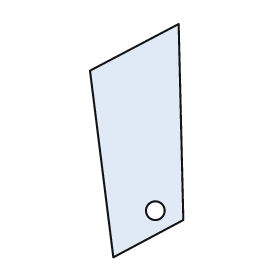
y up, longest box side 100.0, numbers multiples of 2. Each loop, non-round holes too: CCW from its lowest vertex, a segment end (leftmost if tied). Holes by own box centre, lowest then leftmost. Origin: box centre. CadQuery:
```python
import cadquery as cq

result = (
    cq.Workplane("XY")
    .moveTo(-10.0, -50.0)
    .lineTo(20.0, -34.0)
    .lineTo(18.0, 50.0)
    .lineTo(-20.0, 30.0)
    .close()
    .moveTo(8.0, -30.0)
    .circle(4.0)
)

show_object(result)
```